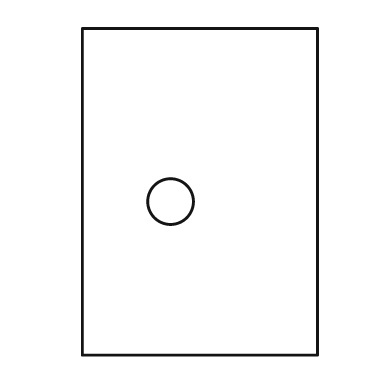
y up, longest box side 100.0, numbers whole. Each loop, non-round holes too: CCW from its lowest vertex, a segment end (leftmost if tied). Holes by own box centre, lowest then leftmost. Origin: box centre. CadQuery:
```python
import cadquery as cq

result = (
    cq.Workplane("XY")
    .moveTo(-36.0, -50.0)
    .lineTo(36.0, -50.0)
    .lineTo(36.0, 50.0)
    .lineTo(-36.0, 50.0)
    .close()
    .moveTo(-9.0, -3.0)
    .circle(7.0)
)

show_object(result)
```